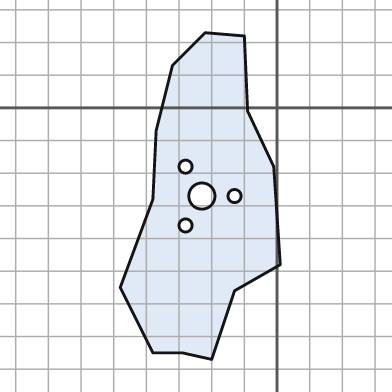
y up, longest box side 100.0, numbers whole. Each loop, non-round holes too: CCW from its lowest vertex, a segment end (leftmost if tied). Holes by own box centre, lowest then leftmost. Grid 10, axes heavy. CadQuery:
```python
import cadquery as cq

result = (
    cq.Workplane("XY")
    .moveTo(-20.0, -77.0)
    .lineTo(-13.0, -56.0)
    .lineTo(1.0, -48.0)
    .lineTo(-1.0, -18.0)
    .lineTo(-9.0, -1.0)
    .lineTo(-10.0, 22.0)
    .lineTo(-22.0, 23.0)
    .lineTo(-32.0, 13.0)
    .lineTo(-37.0, -7.0)
    .lineTo(-38.0, -28.0)
    .lineTo(-48.0, -55.0)
    .lineTo(-38.0, -75.0)
    .lineTo(-29.0, -75.0)
    .close()
    .moveTo(-28.0, -36.0)
    .circle(2.0)
    .moveTo(-23.0, -27.0)
    .circle(4.0)
    .moveTo(-13.0, -27.0)
    .circle(2.0)
    .moveTo(-28.0, -18.0)
    .circle(2.0)
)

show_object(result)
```